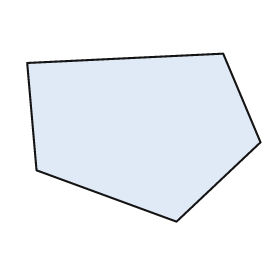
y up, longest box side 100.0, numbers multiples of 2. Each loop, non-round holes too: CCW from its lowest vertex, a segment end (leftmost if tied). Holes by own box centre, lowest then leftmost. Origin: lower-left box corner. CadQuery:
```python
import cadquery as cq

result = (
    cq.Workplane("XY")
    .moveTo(64.0, 0.0)
    .lineTo(100.0, 34.0)
    .lineTo(84.0, 72.0)
    .lineTo(0.0, 68.0)
    .lineTo(4.0, 22.0)
    .close()
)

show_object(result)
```